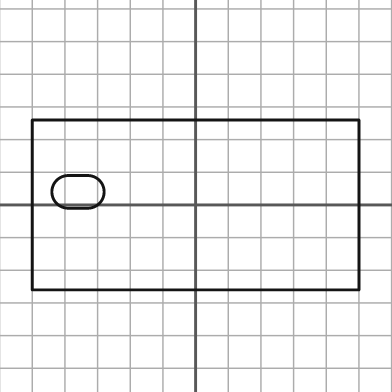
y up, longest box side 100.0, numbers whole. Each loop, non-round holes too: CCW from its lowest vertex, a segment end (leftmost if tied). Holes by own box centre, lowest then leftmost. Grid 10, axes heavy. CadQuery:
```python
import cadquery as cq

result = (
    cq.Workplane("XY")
    .moveTo(-50.0, -26.0)
    .lineTo(50.0, -26.0)
    .lineTo(50.0, 26.0)
    .lineTo(-50.0, 26.0)
    .close()
    .moveTo(-39.0, -1.0)
    .lineTo(-33.0, -1.0)
    .threePointArc((-28.0, 4.0), (-33.0, 9.0))
    .lineTo(-39.0, 9.0)
    .threePointArc((-44.0, 4.0), (-39.0, -1.0))
    .close()
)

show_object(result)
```